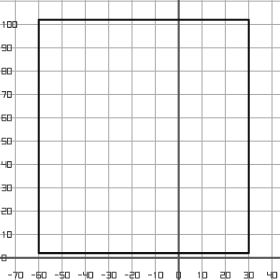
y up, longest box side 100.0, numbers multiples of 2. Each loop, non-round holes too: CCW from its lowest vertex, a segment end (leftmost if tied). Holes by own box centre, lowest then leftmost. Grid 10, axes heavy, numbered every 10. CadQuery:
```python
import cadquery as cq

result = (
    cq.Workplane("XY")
    .moveTo(-60.0, 2.0)
    .lineTo(30.0, 2.0)
    .lineTo(30.0, 102.0)
    .lineTo(-60.0, 102.0)
    .close()
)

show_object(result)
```